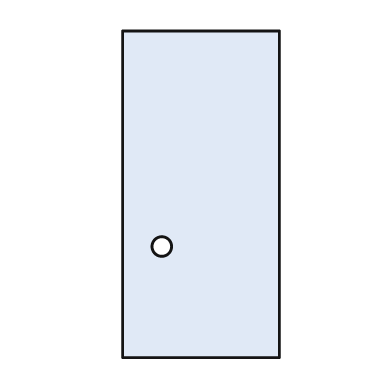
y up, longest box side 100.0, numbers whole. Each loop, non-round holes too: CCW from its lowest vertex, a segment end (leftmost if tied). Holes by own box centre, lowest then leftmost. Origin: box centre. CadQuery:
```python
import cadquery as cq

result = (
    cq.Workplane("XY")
    .moveTo(-24.0, -50.0)
    .lineTo(24.0, -50.0)
    .lineTo(24.0, 50.0)
    .lineTo(-24.0, 50.0)
    .close()
    .moveTo(-12.0, -16.0)
    .circle(3.0)
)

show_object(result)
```